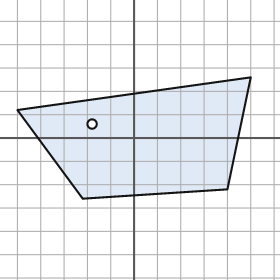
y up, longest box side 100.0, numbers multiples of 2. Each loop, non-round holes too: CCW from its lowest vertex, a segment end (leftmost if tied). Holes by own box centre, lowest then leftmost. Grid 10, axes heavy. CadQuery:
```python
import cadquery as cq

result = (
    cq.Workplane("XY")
    .moveTo(-22.0, -26.0)
    .lineTo(40.0, -22.0)
    .lineTo(50.0, 26.0)
    .lineTo(-50.0, 12.0)
    .close()
    .moveTo(-18.0, 6.0)
    .circle(2.0)
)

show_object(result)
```